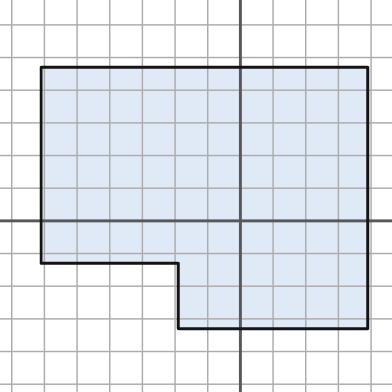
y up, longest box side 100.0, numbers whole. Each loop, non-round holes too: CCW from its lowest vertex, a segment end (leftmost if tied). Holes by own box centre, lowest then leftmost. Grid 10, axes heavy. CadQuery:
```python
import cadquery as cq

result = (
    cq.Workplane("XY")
    .moveTo(-19.0, -33.0)
    .lineTo(39.0, -33.0)
    .lineTo(39.0, 47.0)
    .lineTo(-61.0, 47.0)
    .lineTo(-61.0, -13.0)
    .lineTo(-19.0, -13.0)
    .close()
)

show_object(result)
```